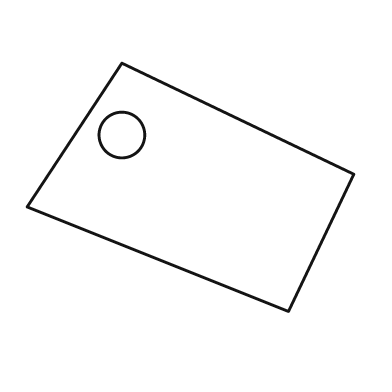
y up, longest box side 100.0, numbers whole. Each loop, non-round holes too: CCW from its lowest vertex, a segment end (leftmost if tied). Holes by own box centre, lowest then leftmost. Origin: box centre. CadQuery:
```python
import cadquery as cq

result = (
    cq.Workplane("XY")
    .moveTo(30.0, -38.0)
    .lineTo(50.0, 4.0)
    .lineTo(-21.0, 38.0)
    .lineTo(-50.0, -6.0)
    .close()
    .moveTo(-21.0, 16.0)
    .circle(7.0)
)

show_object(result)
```